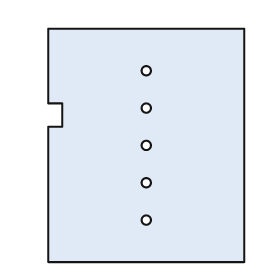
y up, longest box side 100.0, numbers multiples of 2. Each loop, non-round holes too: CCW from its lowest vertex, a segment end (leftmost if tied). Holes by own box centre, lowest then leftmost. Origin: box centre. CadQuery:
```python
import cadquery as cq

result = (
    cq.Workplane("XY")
    .moveTo(-42.0, -50.0)
    .lineTo(42.0, -50.0)
    .lineTo(42.0, 50.0)
    .lineTo(-42.0, 50.0)
    .lineTo(-42.0, 18.0)
    .lineTo(-36.0, 18.0)
    .lineTo(-36.0, 8.0)
    .lineTo(-42.0, 8.0)
    .close()
    .moveTo(0.0, -32.0)
    .circle(2.0)
    .moveTo(0.0, -16.0)
    .circle(2.0)
    .moveTo(0.0, 0.0)
    .circle(2.0)
    .moveTo(0.0, 16.0)
    .circle(2.0)
    .moveTo(0.0, 32.0)
    .circle(2.0)
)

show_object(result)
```